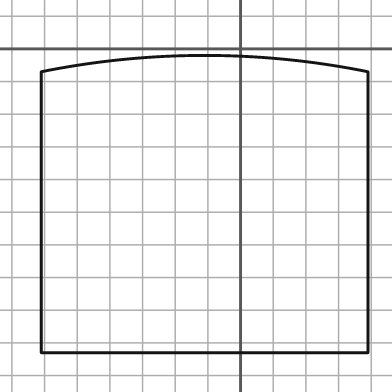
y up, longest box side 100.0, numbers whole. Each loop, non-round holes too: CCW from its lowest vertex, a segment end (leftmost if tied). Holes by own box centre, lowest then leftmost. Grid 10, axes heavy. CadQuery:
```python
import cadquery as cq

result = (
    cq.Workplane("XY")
    .moveTo(-61.0, -93.0)
    .lineTo(39.0, -93.0)
    .lineTo(39.0, -7.0)
    .threePointArc((-11.0, -2.0), (-61.0, -7.0))
    .close()
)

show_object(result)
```